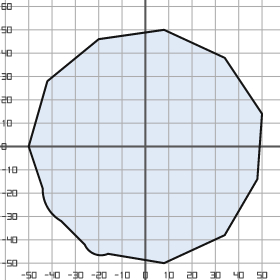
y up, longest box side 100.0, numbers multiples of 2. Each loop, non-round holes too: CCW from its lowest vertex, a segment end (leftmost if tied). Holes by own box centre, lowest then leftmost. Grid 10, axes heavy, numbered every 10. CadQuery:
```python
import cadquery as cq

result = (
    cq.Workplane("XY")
    .moveTo(8.0, -50.0)
    .lineTo(34.0, -38.0)
    .lineTo(48.0, -14.0)
    .lineTo(50.0, 14.0)
    .lineTo(34.0, 38.0)
    .lineTo(8.0, 50.0)
    .lineTo(-20.0, 46.0)
    .lineTo(-42.0, 28.0)
    .lineTo(-50.0, 0.0)
    .lineTo(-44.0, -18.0)
    .threePointArc((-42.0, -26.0), (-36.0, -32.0))
    .lineTo(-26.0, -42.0)
    .threePointArc((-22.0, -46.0), (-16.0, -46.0))
    .close()
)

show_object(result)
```